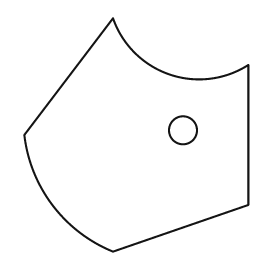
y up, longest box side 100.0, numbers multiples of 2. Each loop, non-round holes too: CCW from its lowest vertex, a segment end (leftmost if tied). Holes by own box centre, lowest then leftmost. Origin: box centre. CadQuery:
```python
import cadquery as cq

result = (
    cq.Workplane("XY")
    .moveTo(-10.0, -50.0)
    .lineTo(48.0, -30.0)
    .lineTo(48.0, 30.0)
    .threePointArc((14.0, 26.0), (-10.0, 50.0))
    .lineTo(-48.0, 0.0)
    .threePointArc((-36.0, -30.0), (-10.0, -50.0))
    .close()
    .moveTo(20.0, 2.0)
    .circle(6.0)
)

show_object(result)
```